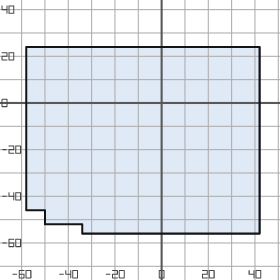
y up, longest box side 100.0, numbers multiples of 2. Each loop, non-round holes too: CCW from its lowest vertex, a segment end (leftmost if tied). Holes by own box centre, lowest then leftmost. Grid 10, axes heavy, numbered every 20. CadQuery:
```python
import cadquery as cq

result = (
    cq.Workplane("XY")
    .moveTo(-34.0, -56.0)
    .lineTo(42.0, -56.0)
    .lineTo(42.0, 24.0)
    .lineTo(-58.0, 24.0)
    .lineTo(-58.0, -46.0)
    .lineTo(-50.0, -46.0)
    .lineTo(-50.0, -52.0)
    .lineTo(-34.0, -52.0)
    .close()
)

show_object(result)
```